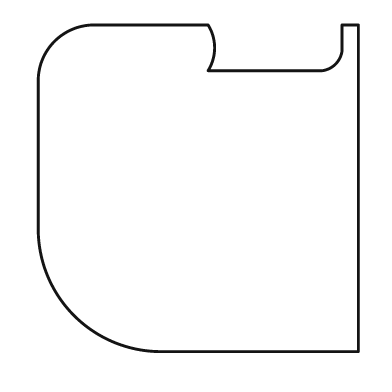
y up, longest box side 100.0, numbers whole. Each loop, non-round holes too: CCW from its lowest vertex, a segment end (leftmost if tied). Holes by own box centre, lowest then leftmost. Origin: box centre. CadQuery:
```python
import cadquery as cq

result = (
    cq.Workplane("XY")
    .moveTo(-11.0, -50.0)
    .lineTo(49.0, -50.0)
    .lineTo(49.0, 50.0)
    .lineTo(44.0, 50.0)
    .lineTo(44.0, 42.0)
    .threePointArc((42.0, 38.0), (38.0, 36.0))
    .lineTo(3.0, 36.0)
    .threePointArc((5.0, 43.0), (3.0, 50.0))
    .lineTo(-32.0, 50.0)
    .threePointArc((-44.0, 45.0), (-49.0, 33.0))
    .lineTo(-49.0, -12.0)
    .threePointArc((-38.0, -39.0), (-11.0, -50.0))
    .close()
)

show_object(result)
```